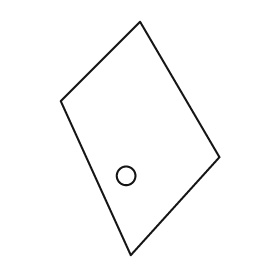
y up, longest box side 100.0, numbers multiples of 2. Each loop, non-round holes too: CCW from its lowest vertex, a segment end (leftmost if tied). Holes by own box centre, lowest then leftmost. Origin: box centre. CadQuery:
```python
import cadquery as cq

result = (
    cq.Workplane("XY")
    .moveTo(-4.0, -50.0)
    .lineTo(34.0, -8.0)
    .lineTo(0.0, 50.0)
    .lineTo(-34.0, 16.0)
    .close()
    .moveTo(-6.0, -16.0)
    .circle(4.0)
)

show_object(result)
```